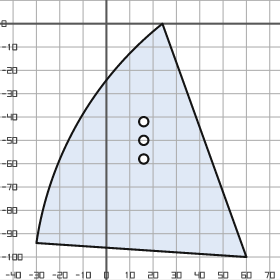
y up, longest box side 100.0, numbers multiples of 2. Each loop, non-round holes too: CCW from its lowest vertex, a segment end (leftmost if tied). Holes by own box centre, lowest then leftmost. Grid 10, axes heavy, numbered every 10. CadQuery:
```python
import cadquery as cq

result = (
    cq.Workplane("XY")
    .moveTo(60.0, -100.0)
    .lineTo(24.0, 0.0)
    .threePointArc((-12.0, -42.0), (-30.0, -94.0))
    .close()
    .moveTo(16.0, -58.0)
    .circle(2.0)
    .moveTo(16.0, -50.0)
    .circle(2.0)
    .moveTo(16.0, -42.0)
    .circle(2.0)
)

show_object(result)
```